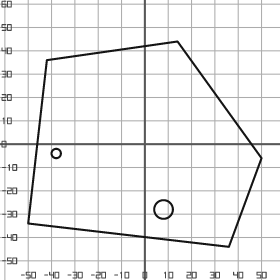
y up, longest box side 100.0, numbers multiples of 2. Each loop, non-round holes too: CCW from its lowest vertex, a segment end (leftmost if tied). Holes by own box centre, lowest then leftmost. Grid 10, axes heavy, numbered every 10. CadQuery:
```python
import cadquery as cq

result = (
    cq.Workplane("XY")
    .moveTo(36.0, -44.0)
    .lineTo(50.0, -6.0)
    .lineTo(14.0, 44.0)
    .lineTo(-42.0, 36.0)
    .lineTo(-50.0, -34.0)
    .close()
    .moveTo(8.0, -28.0)
    .circle(4.0)
    .moveTo(-38.0, -4.0)
    .circle(2.0)
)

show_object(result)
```